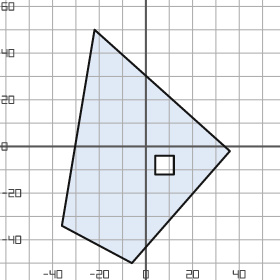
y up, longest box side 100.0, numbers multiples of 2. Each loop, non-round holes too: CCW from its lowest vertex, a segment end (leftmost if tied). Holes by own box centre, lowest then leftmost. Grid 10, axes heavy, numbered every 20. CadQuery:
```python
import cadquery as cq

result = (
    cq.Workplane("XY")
    .moveTo(-6.0, -50.0)
    .lineTo(36.0, -2.0)
    .lineTo(-22.0, 50.0)
    .lineTo(-36.0, -34.0)
    .close()
    .moveTo(4.0, -12.0)
    .lineTo(12.0, -12.0)
    .lineTo(12.0, -4.0)
    .lineTo(4.0, -4.0)
    .close()
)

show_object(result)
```